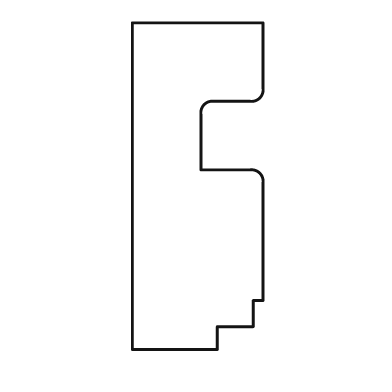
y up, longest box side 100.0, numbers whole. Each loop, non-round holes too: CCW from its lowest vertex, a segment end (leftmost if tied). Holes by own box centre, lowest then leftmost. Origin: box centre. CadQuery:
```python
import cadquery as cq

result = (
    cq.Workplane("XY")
    .moveTo(-20.0, -50.0)
    .lineTo(6.0, -50.0)
    .lineTo(6.0, -43.0)
    .lineTo(17.0, -43.0)
    .lineTo(17.0, -35.0)
    .lineTo(20.0, -35.0)
    .lineTo(20.0, 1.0)
    .threePointArc((19.0, 4.0), (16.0, 5.0))
    .lineTo(1.0, 5.0)
    .lineTo(1.0, 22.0)
    .threePointArc((2.0, 25.0), (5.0, 26.0))
    .lineTo(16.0, 26.0)
    .threePointArc((19.0, 27.0), (20.0, 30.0))
    .lineTo(20.0, 50.0)
    .lineTo(-20.0, 50.0)
    .close()
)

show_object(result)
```